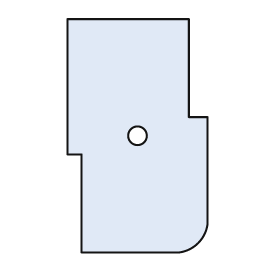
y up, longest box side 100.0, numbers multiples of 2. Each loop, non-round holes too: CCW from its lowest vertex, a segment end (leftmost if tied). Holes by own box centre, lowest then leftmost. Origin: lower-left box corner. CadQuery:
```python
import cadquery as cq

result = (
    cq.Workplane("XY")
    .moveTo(6.0, 0.0)
    .lineTo(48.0, 0.0)
    .threePointArc((56.0, 4.0), (60.0, 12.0))
    .lineTo(60.0, 58.0)
    .lineTo(52.0, 58.0)
    .lineTo(52.0, 100.0)
    .lineTo(0.0, 100.0)
    .lineTo(0.0, 42.0)
    .lineTo(6.0, 42.0)
    .close()
    .moveTo(30.0, 50.0)
    .circle(4.0)
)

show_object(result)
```